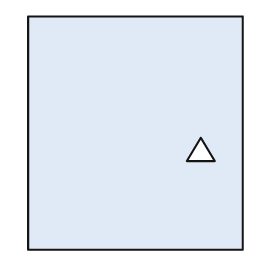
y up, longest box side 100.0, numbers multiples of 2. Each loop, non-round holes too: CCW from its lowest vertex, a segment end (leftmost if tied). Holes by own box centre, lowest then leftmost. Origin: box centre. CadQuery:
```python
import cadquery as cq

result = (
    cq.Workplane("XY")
    .moveTo(-46.0, -50.0)
    .lineTo(46.0, -50.0)
    .lineTo(46.0, 50.0)
    .lineTo(-46.0, 50.0)
    .close()
    .moveTo(22.0, -12.0)
    .lineTo(34.0, -12.0)
    .lineTo(28.0, -2.0)
    .close()
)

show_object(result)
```